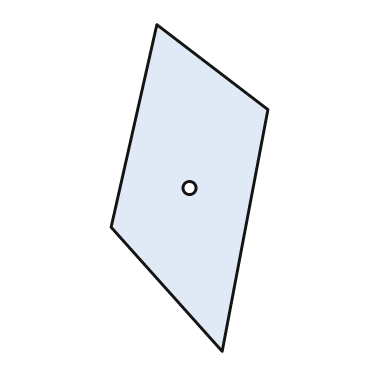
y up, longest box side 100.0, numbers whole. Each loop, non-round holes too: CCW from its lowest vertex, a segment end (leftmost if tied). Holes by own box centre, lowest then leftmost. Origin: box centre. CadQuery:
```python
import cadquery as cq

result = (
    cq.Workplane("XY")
    .moveTo(10.0, -50.0)
    .lineTo(24.0, 24.0)
    .lineTo(-10.0, 50.0)
    .lineTo(-24.0, -12.0)
    .close()
    .moveTo(0.0, 0.0)
    .circle(2.0)
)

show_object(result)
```